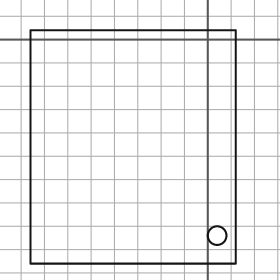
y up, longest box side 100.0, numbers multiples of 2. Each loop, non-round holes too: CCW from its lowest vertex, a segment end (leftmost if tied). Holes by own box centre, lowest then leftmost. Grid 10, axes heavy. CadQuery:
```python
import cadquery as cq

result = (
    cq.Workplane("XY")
    .moveTo(-76.0, -96.0)
    .lineTo(12.0, -96.0)
    .lineTo(12.0, 4.0)
    .lineTo(-76.0, 4.0)
    .close()
    .moveTo(4.0, -84.0)
    .circle(4.0)
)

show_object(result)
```